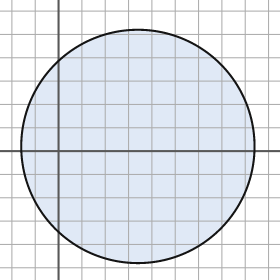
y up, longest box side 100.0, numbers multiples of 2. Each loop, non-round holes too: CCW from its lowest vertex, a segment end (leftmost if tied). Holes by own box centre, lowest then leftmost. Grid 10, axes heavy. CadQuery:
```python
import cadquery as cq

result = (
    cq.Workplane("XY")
    .moveTo(34.0, 2.0)
    .circle(50.0)
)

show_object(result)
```